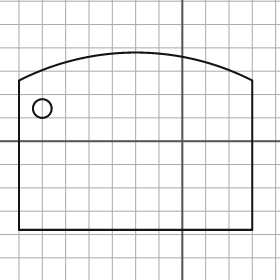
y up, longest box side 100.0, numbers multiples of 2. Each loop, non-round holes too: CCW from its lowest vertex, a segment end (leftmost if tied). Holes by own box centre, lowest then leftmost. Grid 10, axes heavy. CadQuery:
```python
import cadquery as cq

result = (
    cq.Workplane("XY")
    .moveTo(-70.0, -38.0)
    .lineTo(30.0, -38.0)
    .lineTo(30.0, 26.0)
    .threePointArc((-20.0, 38.0), (-70.0, 26.0))
    .close()
    .moveTo(-60.0, 14.0)
    .circle(4.0)
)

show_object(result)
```